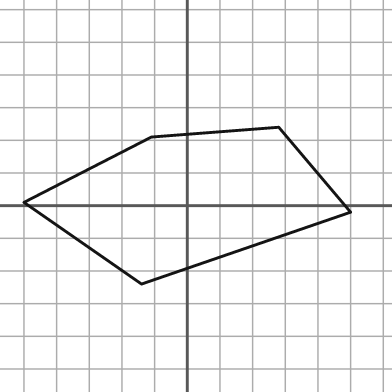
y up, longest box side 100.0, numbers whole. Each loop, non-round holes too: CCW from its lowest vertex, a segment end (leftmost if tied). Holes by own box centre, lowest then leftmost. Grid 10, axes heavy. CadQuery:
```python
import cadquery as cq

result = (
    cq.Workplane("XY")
    .moveTo(-14.0, -24.0)
    .lineTo(50.0, -2.0)
    .lineTo(28.0, 24.0)
    .lineTo(-11.0, 21.0)
    .lineTo(-50.0, 1.0)
    .close()
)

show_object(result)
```